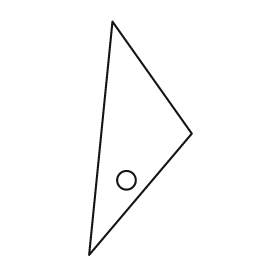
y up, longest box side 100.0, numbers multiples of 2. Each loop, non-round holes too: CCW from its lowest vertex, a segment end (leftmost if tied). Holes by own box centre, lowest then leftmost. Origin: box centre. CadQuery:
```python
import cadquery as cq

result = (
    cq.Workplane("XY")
    .moveTo(-22.0, -50.0)
    .lineTo(22.0, 2.0)
    .lineTo(-12.0, 50.0)
    .close()
    .moveTo(-6.0, -18.0)
    .circle(4.0)
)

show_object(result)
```